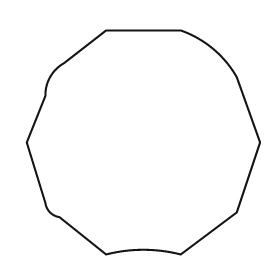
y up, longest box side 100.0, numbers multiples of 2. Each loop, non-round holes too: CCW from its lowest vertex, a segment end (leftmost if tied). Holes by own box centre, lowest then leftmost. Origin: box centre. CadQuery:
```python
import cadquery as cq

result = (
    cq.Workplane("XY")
    .moveTo(-16.0, -48.0)
    .threePointArc((0.0, -46.0), (16.0, -48.0))
    .lineTo(40.0, -30.0)
    .lineTo(50.0, 0.0)
    .lineTo(40.0, 28.0)
    .threePointArc((30.0, 40.0), (16.0, 48.0))
    .lineTo(-16.0, 48.0)
    .lineTo(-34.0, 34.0)
    .threePointArc((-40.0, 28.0), (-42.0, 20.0))
    .lineTo(-50.0, 0.0)
    .lineTo(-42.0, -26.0)
    .threePointArc((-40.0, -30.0), (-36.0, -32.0))
    .close()
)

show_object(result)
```